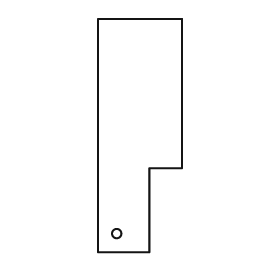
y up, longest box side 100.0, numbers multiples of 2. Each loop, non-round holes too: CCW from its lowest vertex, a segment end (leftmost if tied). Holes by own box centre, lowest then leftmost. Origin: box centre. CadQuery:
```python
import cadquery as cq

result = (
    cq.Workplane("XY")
    .moveTo(-18.0, -50.0)
    .lineTo(4.0, -50.0)
    .lineTo(4.0, -14.0)
    .lineTo(18.0, -14.0)
    .lineTo(18.0, 50.0)
    .lineTo(-18.0, 50.0)
    .close()
    .moveTo(-10.0, -42.0)
    .circle(2.0)
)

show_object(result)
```